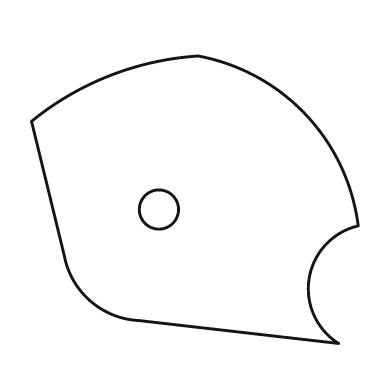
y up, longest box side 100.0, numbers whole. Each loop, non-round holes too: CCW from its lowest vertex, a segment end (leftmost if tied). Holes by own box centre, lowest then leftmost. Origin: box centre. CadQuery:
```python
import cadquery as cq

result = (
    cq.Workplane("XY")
    .moveTo(44.0, -44.0)
    .threePointArc((35.0, -24.0), (50.0, -8.0))
    .threePointArc((34.0, 26.0), (1.0, 44.0))
    .threePointArc((-26.0, 38.0), (-50.0, 24.0))
    .lineTo(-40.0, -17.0)
    .threePointArc((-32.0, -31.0), (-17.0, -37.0))
    .close()
    .moveTo(-11.0, -3.0)
    .circle(6.0)
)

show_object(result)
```